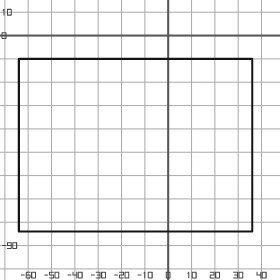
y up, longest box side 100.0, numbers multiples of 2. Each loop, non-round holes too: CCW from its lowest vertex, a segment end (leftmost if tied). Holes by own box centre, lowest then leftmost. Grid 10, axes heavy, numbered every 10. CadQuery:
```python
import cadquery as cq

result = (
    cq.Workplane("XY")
    .moveTo(-64.0, -84.0)
    .lineTo(36.0, -84.0)
    .lineTo(36.0, -10.0)
    .lineTo(-64.0, -10.0)
    .close()
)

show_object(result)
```